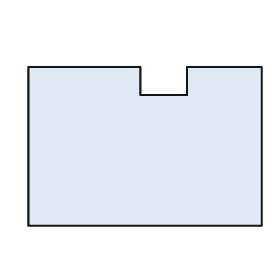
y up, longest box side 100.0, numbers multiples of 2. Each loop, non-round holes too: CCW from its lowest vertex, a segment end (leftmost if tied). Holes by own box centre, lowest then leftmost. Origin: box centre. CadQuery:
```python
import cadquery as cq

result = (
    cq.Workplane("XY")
    .moveTo(-50.0, -34.0)
    .lineTo(50.0, -34.0)
    .lineTo(50.0, 34.0)
    .lineTo(18.0, 34.0)
    .lineTo(18.0, 22.0)
    .lineTo(-2.0, 22.0)
    .lineTo(-2.0, 34.0)
    .lineTo(-50.0, 34.0)
    .close()
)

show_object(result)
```